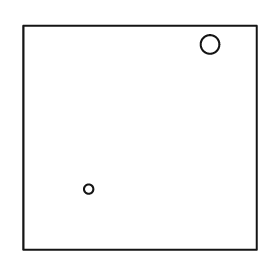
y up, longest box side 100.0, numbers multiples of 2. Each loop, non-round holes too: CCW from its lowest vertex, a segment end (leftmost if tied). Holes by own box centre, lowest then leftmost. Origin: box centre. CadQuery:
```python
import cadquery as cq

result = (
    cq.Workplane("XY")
    .moveTo(-50.0, -48.0)
    .lineTo(50.0, -48.0)
    .lineTo(50.0, 48.0)
    .lineTo(-50.0, 48.0)
    .close()
    .moveTo(-22.0, -22.0)
    .circle(2.0)
    .moveTo(30.0, 40.0)
    .circle(4.0)
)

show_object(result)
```